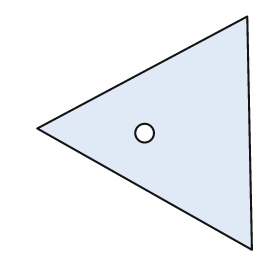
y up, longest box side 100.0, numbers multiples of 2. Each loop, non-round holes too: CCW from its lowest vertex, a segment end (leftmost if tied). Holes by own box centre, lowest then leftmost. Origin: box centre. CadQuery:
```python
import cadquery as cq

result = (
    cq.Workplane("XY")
    .moveTo(46.0, -50.0)
    .lineTo(44.0, 50.0)
    .lineTo(-46.0, 2.0)
    .close()
    .moveTo(0.0, 0.0)
    .circle(4.0)
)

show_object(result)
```